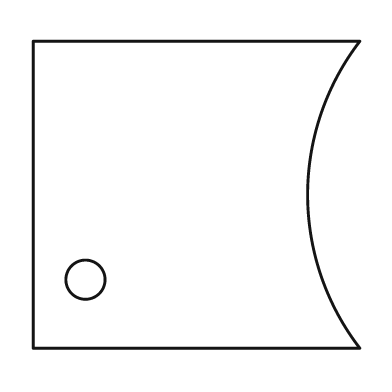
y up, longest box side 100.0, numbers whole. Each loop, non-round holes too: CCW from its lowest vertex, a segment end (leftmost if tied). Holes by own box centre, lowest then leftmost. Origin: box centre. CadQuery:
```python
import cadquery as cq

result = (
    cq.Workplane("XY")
    .moveTo(-50.0, -47.0)
    .lineTo(50.0, -47.0)
    .threePointArc((34.0, 0.0), (50.0, 47.0))
    .lineTo(-50.0, 47.0)
    .close()
    .moveTo(-34.0, -26.0)
    .circle(6.0)
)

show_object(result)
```